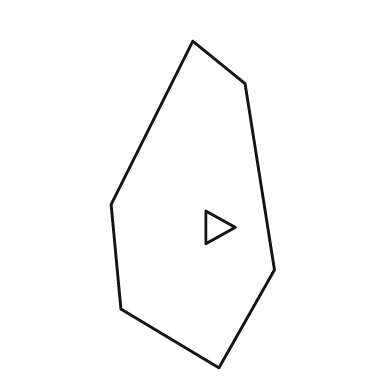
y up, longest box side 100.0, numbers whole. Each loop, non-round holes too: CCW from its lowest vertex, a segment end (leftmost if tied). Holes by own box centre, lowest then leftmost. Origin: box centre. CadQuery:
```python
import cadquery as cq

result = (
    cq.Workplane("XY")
    .moveTo(8.0, -50.0)
    .lineTo(25.0, -20.0)
    .lineTo(16.0, 37.0)
    .lineTo(0.0, 50.0)
    .lineTo(-25.0, 0.0)
    .lineTo(-22.0, -32.0)
    .close()
    .moveTo(4.0, -12.0)
    .lineTo(13.0, -7.0)
    .lineTo(4.0, -2.0)
    .close()
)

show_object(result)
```